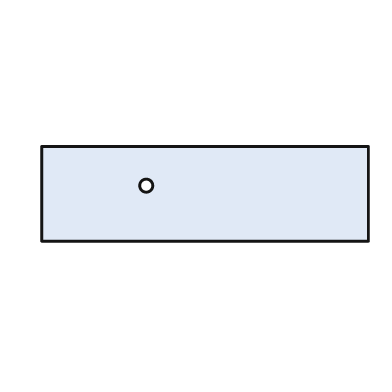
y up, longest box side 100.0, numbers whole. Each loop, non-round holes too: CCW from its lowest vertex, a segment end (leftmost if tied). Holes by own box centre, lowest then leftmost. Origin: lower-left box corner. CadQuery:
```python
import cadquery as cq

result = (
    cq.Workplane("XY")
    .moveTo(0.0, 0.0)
    .lineTo(100.0, 0.0)
    .lineTo(100.0, 29.0)
    .lineTo(0.0, 29.0)
    .close()
    .moveTo(32.0, 17.0)
    .circle(2.0)
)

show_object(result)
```